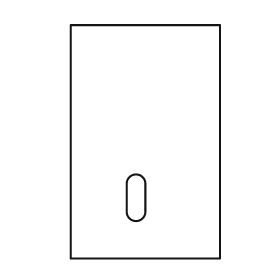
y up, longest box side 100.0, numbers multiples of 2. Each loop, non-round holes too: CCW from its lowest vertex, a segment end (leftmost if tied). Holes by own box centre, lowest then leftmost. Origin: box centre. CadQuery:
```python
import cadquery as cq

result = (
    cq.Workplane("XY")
    .moveTo(-32.0, -50.0)
    .lineTo(32.0, -50.0)
    .lineTo(32.0, 50.0)
    .lineTo(-32.0, 50.0)
    .close()
    .moveTo(-8.0, -30.0)
    .threePointArc((-4.0, -34.0), (0.0, -30.0))
    .lineTo(0.0, -18.0)
    .threePointArc((-4.0, -14.0), (-8.0, -18.0))
    .close()
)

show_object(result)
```